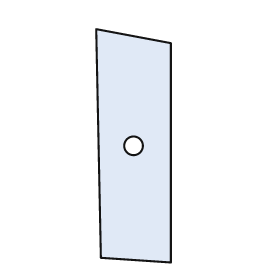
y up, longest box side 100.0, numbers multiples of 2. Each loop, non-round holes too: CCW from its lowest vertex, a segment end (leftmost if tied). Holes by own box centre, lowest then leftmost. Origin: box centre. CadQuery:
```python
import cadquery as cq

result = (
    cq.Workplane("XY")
    .moveTo(16.0, -50.0)
    .lineTo(16.0, 44.0)
    .lineTo(-16.0, 50.0)
    .lineTo(-14.0, -48.0)
    .close()
    .moveTo(0.0, 0.0)
    .circle(4.0)
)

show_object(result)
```